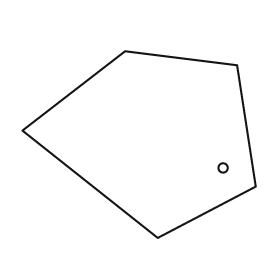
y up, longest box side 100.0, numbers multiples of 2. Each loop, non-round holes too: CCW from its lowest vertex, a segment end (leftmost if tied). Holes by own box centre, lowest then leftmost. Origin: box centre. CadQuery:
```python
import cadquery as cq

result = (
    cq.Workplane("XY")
    .moveTo(8.0, -40.0)
    .lineTo(50.0, -18.0)
    .lineTo(42.0, 34.0)
    .lineTo(-6.0, 40.0)
    .lineTo(-50.0, 6.0)
    .close()
    .moveTo(36.0, -10.0)
    .circle(2.0)
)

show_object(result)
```